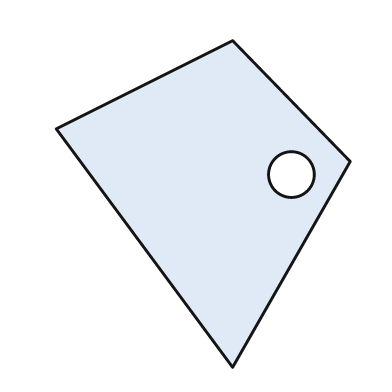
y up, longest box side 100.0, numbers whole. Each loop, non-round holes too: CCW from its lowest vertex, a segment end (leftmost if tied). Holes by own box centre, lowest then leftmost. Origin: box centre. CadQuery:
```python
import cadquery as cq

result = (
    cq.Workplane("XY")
    .moveTo(9.0, -50.0)
    .lineTo(45.0, 13.0)
    .lineTo(9.0, 50.0)
    .lineTo(-45.0, 23.0)
    .close()
    .moveTo(27.0, 9.0)
    .circle(7.0)
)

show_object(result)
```